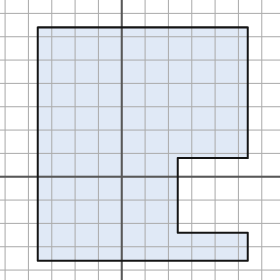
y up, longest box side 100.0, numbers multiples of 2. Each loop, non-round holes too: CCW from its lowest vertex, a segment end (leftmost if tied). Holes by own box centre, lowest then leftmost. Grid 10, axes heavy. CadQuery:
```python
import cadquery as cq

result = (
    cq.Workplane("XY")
    .moveTo(-36.0, -36.0)
    .lineTo(54.0, -36.0)
    .lineTo(54.0, -24.0)
    .lineTo(24.0, -24.0)
    .lineTo(24.0, 8.0)
    .lineTo(54.0, 8.0)
    .lineTo(54.0, 64.0)
    .lineTo(-36.0, 64.0)
    .close()
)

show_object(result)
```